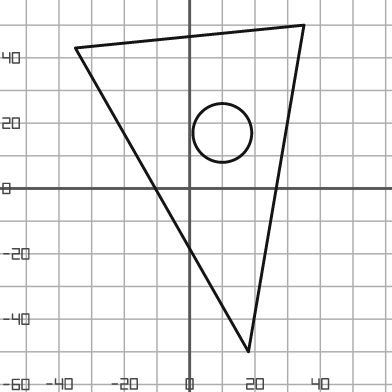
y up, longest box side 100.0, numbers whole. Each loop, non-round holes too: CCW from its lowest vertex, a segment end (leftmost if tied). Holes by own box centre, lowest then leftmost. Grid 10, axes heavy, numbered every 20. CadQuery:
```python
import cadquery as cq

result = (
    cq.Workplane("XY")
    .moveTo(18.0, -50.0)
    .lineTo(35.0, 50.0)
    .lineTo(-35.0, 43.0)
    .close()
    .moveTo(10.0, 17.0)
    .circle(9.0)
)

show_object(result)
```